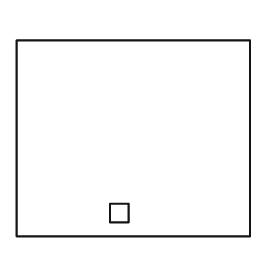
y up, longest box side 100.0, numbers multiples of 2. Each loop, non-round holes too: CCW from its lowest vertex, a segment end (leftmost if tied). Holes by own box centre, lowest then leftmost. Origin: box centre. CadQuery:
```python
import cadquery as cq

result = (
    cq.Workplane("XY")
    .moveTo(-50.0, -42.0)
    .lineTo(50.0, -42.0)
    .lineTo(50.0, 42.0)
    .lineTo(-50.0, 42.0)
    .close()
    .moveTo(-10.0, -36.0)
    .lineTo(-2.0, -36.0)
    .lineTo(-2.0, -28.0)
    .lineTo(-10.0, -28.0)
    .close()
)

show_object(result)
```